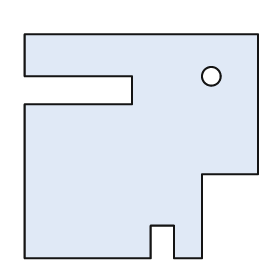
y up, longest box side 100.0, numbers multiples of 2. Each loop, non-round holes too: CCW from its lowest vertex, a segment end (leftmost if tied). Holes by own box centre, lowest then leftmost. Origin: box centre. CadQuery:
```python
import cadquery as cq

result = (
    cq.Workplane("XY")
    .moveTo(-50.0, -48.0)
    .lineTo(4.0, -48.0)
    .lineTo(4.0, -34.0)
    .lineTo(14.0, -34.0)
    .lineTo(14.0, -48.0)
    .lineTo(26.0, -48.0)
    .lineTo(26.0, -12.0)
    .lineTo(50.0, -12.0)
    .lineTo(50.0, 48.0)
    .lineTo(-50.0, 48.0)
    .lineTo(-50.0, 30.0)
    .lineTo(-4.0, 30.0)
    .lineTo(-4.0, 18.0)
    .lineTo(-50.0, 18.0)
    .close()
    .moveTo(30.0, 30.0)
    .circle(4.0)
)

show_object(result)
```